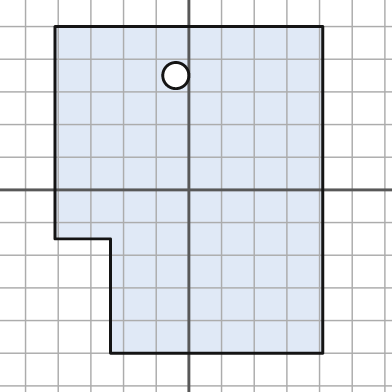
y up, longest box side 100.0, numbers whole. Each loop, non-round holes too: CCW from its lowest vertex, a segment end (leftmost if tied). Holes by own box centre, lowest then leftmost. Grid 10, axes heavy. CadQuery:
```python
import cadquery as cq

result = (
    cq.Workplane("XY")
    .moveTo(-24.0, -50.0)
    .lineTo(41.0, -50.0)
    .lineTo(41.0, 50.0)
    .lineTo(-41.0, 50.0)
    .lineTo(-41.0, -15.0)
    .lineTo(-24.0, -15.0)
    .close()
    .moveTo(-4.0, 35.0)
    .circle(4.0)
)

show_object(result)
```